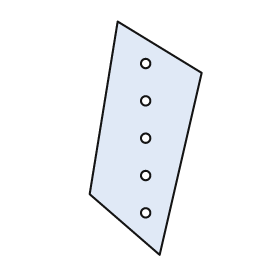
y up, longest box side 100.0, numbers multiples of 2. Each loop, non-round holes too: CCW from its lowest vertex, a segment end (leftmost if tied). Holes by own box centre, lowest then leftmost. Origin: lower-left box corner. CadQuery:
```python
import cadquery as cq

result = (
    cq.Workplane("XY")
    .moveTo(30.0, 0.0)
    .lineTo(48.0, 78.0)
    .lineTo(12.0, 100.0)
    .lineTo(0.0, 26.0)
    .close()
    .moveTo(24.0, 18.0)
    .circle(2.0)
    .moveTo(24.0, 34.0)
    .circle(2.0)
    .moveTo(24.0, 50.0)
    .circle(2.0)
    .moveTo(24.0, 66.0)
    .circle(2.0)
    .moveTo(24.0, 82.0)
    .circle(2.0)
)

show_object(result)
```